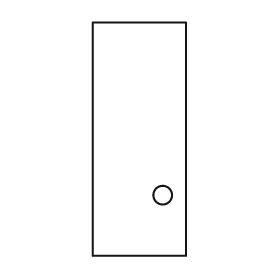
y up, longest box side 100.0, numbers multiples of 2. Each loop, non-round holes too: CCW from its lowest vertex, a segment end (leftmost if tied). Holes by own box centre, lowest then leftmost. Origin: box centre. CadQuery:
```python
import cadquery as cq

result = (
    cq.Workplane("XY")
    .moveTo(-20.0, -50.0)
    .lineTo(20.0, -50.0)
    .lineTo(20.0, 50.0)
    .lineTo(-20.0, 50.0)
    .close()
    .moveTo(10.0, -24.0)
    .circle(4.0)
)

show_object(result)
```